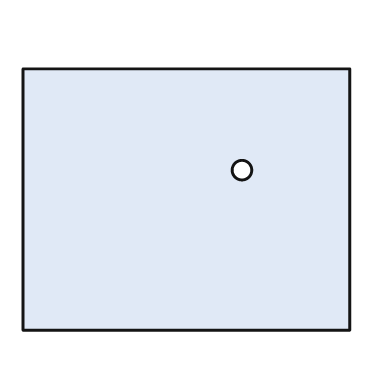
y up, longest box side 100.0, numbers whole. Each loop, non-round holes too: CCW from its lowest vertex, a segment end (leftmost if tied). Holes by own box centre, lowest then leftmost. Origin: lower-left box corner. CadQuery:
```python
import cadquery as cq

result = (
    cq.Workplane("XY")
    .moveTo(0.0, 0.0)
    .lineTo(100.0, 0.0)
    .lineTo(100.0, 80.0)
    .lineTo(0.0, 80.0)
    .close()
    .moveTo(67.0, 49.0)
    .circle(3.0)
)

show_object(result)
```